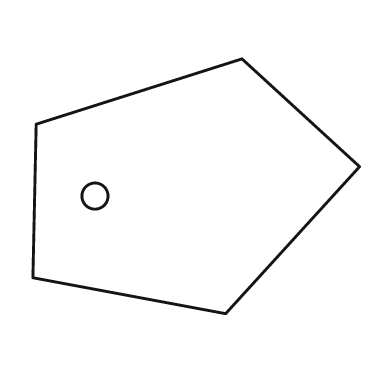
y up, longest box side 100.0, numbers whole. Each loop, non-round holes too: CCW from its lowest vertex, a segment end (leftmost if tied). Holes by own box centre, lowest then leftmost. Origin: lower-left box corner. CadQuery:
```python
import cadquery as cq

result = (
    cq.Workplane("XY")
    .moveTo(59.0, 0.0)
    .lineTo(100.0, 45.0)
    .lineTo(64.0, 78.0)
    .lineTo(1.0, 58.0)
    .lineTo(0.0, 11.0)
    .close()
    .moveTo(19.0, 36.0)
    .circle(4.0)
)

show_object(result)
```